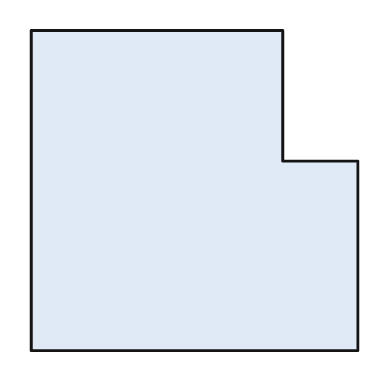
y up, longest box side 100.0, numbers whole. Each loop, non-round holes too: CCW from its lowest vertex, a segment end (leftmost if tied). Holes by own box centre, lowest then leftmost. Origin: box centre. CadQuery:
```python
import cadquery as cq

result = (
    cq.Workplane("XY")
    .moveTo(-50.0, -49.0)
    .lineTo(50.0, -49.0)
    .lineTo(50.0, 9.0)
    .lineTo(27.0, 9.0)
    .lineTo(27.0, 49.0)
    .lineTo(-50.0, 49.0)
    .close()
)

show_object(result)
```